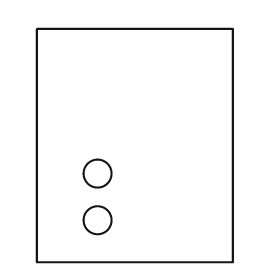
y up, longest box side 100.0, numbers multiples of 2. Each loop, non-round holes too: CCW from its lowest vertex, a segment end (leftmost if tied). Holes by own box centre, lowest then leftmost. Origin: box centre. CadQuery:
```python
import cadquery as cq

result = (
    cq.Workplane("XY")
    .moveTo(-42.0, -50.0)
    .lineTo(42.0, -50.0)
    .lineTo(42.0, 50.0)
    .lineTo(-42.0, 50.0)
    .close()
    .moveTo(-16.0, -32.0)
    .circle(6.0)
    .moveTo(-16.0, -12.0)
    .circle(6.0)
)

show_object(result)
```